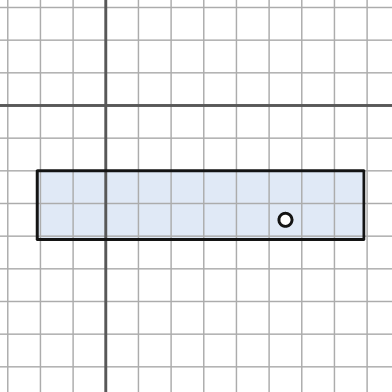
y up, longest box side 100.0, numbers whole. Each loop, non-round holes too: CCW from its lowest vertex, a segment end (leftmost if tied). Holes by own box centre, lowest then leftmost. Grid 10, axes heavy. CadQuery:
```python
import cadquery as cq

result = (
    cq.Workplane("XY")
    .moveTo(-21.0, -41.0)
    .lineTo(79.0, -41.0)
    .lineTo(79.0, -20.0)
    .lineTo(-21.0, -20.0)
    .close()
    .moveTo(55.0, -35.0)
    .circle(2.0)
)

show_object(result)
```